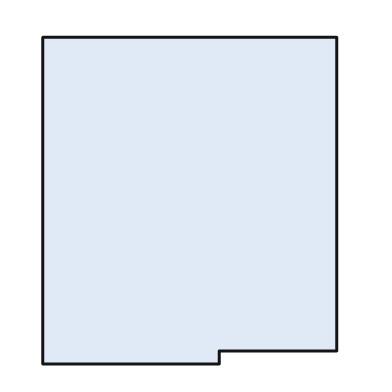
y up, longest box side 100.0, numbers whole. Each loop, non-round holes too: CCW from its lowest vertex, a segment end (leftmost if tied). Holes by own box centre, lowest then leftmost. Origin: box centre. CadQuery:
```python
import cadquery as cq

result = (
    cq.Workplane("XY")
    .moveTo(-45.0, -50.0)
    .lineTo(9.0, -50.0)
    .lineTo(9.0, -46.0)
    .lineTo(45.0, -46.0)
    .lineTo(45.0, 50.0)
    .lineTo(-45.0, 50.0)
    .close()
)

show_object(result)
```